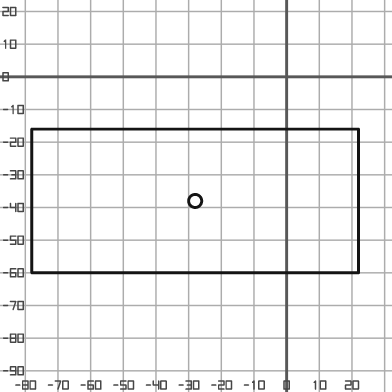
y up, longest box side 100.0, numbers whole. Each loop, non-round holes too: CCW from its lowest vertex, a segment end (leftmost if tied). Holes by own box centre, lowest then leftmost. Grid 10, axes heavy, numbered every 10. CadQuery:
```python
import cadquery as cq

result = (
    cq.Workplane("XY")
    .moveTo(-78.0, -60.0)
    .lineTo(22.0, -60.0)
    .lineTo(22.0, -16.0)
    .lineTo(-78.0, -16.0)
    .close()
    .moveTo(-28.0, -38.0)
    .circle(2.0)
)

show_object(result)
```